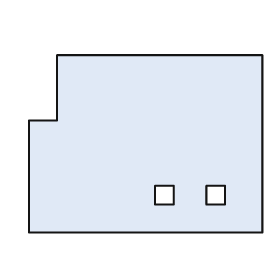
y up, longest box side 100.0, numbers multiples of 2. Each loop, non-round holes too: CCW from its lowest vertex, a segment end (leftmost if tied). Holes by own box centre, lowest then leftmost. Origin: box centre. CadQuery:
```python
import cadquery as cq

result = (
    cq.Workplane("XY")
    .moveTo(-50.0, -38.0)
    .lineTo(50.0, -38.0)
    .lineTo(50.0, 38.0)
    .lineTo(-38.0, 38.0)
    .lineTo(-38.0, 10.0)
    .lineTo(-50.0, 10.0)
    .close()
    .moveTo(4.0, -26.0)
    .lineTo(12.0, -26.0)
    .lineTo(12.0, -18.0)
    .lineTo(4.0, -18.0)
    .close()
    .moveTo(26.0, -26.0)
    .lineTo(34.0, -26.0)
    .lineTo(34.0, -18.0)
    .lineTo(26.0, -18.0)
    .close()
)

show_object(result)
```